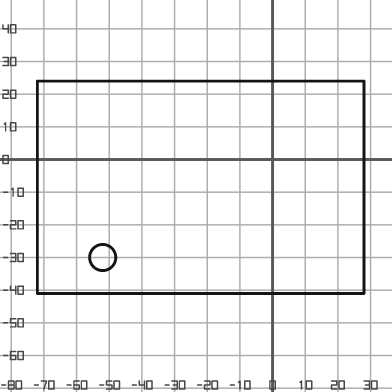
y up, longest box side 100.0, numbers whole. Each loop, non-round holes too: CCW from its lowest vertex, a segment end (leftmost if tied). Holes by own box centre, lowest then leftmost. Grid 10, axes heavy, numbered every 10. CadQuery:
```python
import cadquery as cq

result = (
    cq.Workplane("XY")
    .moveTo(-72.0, -41.0)
    .lineTo(28.0, -41.0)
    .lineTo(28.0, 24.0)
    .lineTo(-72.0, 24.0)
    .close()
    .moveTo(-52.0, -30.0)
    .circle(4.0)
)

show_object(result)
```